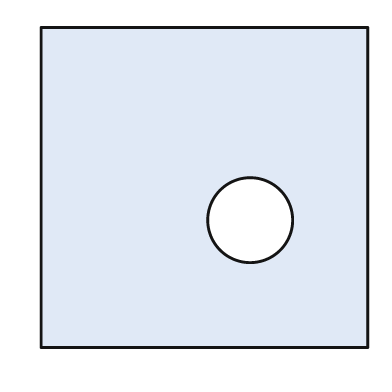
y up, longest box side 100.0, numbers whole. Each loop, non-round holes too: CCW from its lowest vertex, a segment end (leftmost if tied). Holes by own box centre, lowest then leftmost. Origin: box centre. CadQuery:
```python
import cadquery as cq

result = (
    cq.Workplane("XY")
    .moveTo(-50.0, -49.0)
    .lineTo(50.0, -49.0)
    .lineTo(50.0, 49.0)
    .lineTo(-50.0, 49.0)
    .close()
    .moveTo(14.0, -10.0)
    .circle(13.0)
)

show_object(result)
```